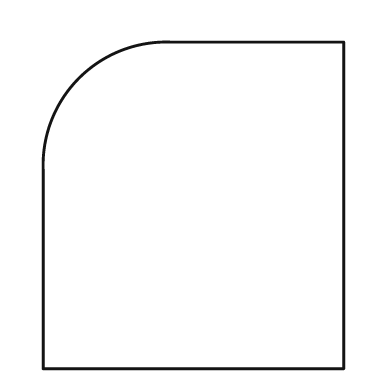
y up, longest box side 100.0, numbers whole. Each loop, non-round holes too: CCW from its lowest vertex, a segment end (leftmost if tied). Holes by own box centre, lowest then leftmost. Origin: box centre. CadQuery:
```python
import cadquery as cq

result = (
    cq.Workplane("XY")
    .moveTo(-46.0, -50.0)
    .lineTo(46.0, -50.0)
    .lineTo(46.0, 50.0)
    .lineTo(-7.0, 50.0)
    .threePointArc((-35.0, 39.0), (-46.0, 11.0))
    .close()
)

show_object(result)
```